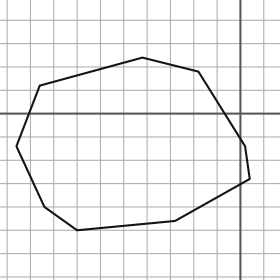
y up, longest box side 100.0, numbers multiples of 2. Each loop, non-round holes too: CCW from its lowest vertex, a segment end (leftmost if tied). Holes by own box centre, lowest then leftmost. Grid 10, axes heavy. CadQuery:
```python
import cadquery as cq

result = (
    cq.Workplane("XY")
    .moveTo(-70.0, -50.0)
    .lineTo(-28.0, -46.0)
    .lineTo(4.0, -28.0)
    .lineTo(2.0, -14.0)
    .lineTo(-18.0, 18.0)
    .lineTo(-42.0, 24.0)
    .lineTo(-86.0, 12.0)
    .lineTo(-96.0, -14.0)
    .lineTo(-84.0, -40.0)
    .close()
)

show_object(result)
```